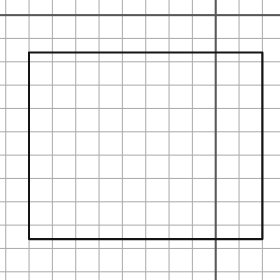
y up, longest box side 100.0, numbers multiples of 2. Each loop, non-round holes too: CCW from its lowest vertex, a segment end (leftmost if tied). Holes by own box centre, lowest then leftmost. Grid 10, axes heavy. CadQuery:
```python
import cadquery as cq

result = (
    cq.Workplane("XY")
    .moveTo(-80.0, -96.0)
    .lineTo(20.0, -96.0)
    .lineTo(20.0, -16.0)
    .lineTo(-80.0, -16.0)
    .close()
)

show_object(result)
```